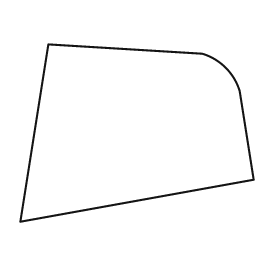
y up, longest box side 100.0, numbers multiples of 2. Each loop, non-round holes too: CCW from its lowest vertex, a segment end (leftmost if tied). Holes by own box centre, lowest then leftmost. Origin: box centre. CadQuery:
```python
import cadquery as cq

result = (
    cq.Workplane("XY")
    .moveTo(-50.0, -38.0)
    .lineTo(50.0, -20.0)
    .lineTo(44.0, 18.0)
    .threePointArc((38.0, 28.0), (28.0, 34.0))
    .lineTo(-38.0, 38.0)
    .close()
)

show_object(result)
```